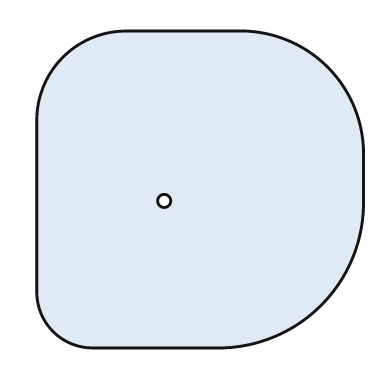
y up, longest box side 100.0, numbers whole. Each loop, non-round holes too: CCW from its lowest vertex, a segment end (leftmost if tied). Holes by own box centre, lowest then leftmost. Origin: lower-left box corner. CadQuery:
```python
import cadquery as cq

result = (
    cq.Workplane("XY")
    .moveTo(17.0, 0.0)
    .lineTo(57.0, 0.0)
    .threePointArc((87.0, 13.0), (100.0, 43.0))
    .lineTo(100.0, 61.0)
    .threePointArc((89.0, 86.0), (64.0, 97.0))
    .lineTo(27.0, 97.0)
    .threePointArc((8.0, 89.0), (0.0, 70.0))
    .lineTo(0.0, 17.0)
    .threePointArc((5.0, 5.0), (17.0, 0.0))
    .close()
    .moveTo(39.0, 45.0)
    .circle(2.0)
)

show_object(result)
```